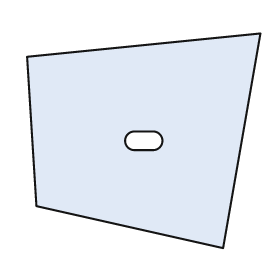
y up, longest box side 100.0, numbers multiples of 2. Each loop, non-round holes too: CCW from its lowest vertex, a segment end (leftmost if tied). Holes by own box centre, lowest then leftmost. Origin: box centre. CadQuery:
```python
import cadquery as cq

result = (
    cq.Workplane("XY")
    .moveTo(34.0, -46.0)
    .lineTo(50.0, 46.0)
    .lineTo(-50.0, 36.0)
    .lineTo(-46.0, -28.0)
    .close()
    .moveTo(-4.0, -4.0)
    .lineTo(4.0, -4.0)
    .threePointArc((8.0, 0.0), (4.0, 4.0))
    .lineTo(-4.0, 4.0)
    .threePointArc((-8.0, 0.0), (-4.0, -4.0))
    .close()
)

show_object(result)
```